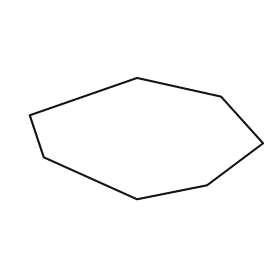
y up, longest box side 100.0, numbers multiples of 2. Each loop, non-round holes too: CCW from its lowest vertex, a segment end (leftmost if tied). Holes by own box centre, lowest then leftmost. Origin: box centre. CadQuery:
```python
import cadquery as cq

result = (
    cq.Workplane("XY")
    .moveTo(-4.0, -26.0)
    .lineTo(26.0, -20.0)
    .lineTo(50.0, -2.0)
    .lineTo(32.0, 18.0)
    .lineTo(-4.0, 26.0)
    .lineTo(-50.0, 10.0)
    .lineTo(-44.0, -8.0)
    .close()
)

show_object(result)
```